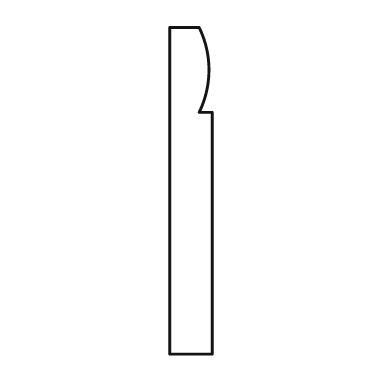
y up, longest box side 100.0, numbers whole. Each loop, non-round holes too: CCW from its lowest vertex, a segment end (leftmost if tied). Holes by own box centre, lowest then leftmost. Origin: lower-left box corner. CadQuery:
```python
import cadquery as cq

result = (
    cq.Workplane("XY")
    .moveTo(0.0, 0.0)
    .lineTo(13.0, 0.0)
    .lineTo(13.0, 74.0)
    .lineTo(9.0, 74.0)
    .threePointArc((12.0, 87.0), (9.0, 100.0))
    .lineTo(0.0, 100.0)
    .close()
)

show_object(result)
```